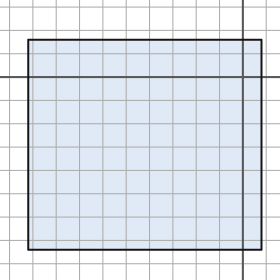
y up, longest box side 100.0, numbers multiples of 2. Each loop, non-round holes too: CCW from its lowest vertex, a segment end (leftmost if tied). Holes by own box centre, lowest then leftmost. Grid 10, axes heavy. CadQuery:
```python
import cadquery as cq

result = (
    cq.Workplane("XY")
    .moveTo(-92.0, -74.0)
    .lineTo(8.0, -74.0)
    .lineTo(8.0, 16.0)
    .lineTo(-92.0, 16.0)
    .close()
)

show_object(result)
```